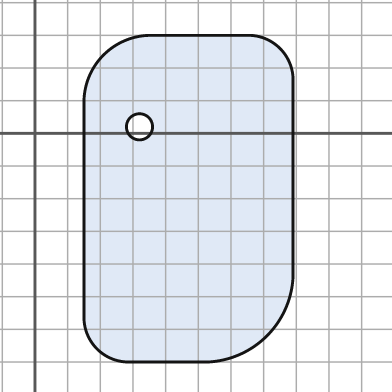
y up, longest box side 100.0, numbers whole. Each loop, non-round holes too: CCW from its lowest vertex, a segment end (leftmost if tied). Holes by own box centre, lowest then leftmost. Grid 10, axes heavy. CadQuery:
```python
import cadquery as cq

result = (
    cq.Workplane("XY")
    .moveTo(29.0, -70.0)
    .lineTo(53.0, -70.0)
    .threePointArc((71.0, -62.0), (79.0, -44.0))
    .lineTo(79.0, 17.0)
    .threePointArc((75.0, 26.0), (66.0, 30.0))
    .lineTo(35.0, 30.0)
    .threePointArc((21.0, 24.0), (15.0, 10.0))
    .lineTo(15.0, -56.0)
    .threePointArc((19.0, -66.0), (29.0, -70.0))
    .close()
    .moveTo(32.0, 2.0)
    .circle(4.0)
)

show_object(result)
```